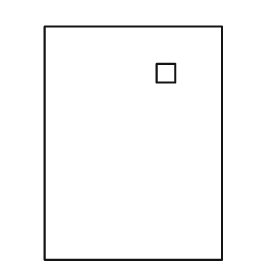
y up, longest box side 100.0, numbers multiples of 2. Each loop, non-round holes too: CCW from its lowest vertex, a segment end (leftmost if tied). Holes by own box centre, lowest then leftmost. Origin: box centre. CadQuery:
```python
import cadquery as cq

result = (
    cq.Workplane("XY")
    .moveTo(-38.0, -50.0)
    .lineTo(38.0, -50.0)
    .lineTo(38.0, 50.0)
    .lineTo(-38.0, 50.0)
    .close()
    .moveTo(10.0, 26.0)
    .lineTo(18.0, 26.0)
    .lineTo(18.0, 34.0)
    .lineTo(10.0, 34.0)
    .close()
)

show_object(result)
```